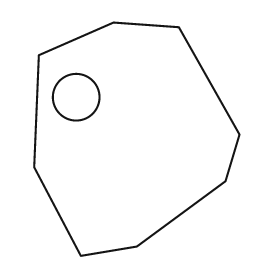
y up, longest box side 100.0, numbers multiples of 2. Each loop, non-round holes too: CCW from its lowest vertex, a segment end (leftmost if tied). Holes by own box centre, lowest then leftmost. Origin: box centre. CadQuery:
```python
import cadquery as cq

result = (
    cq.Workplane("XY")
    .moveTo(-24.0, -50.0)
    .lineTo(0.0, -46.0)
    .lineTo(38.0, -18.0)
    .lineTo(44.0, 2.0)
    .lineTo(18.0, 48.0)
    .lineTo(-10.0, 50.0)
    .lineTo(-42.0, 36.0)
    .lineTo(-44.0, -12.0)
    .close()
    .moveTo(-26.0, 18.0)
    .circle(10.0)
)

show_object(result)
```